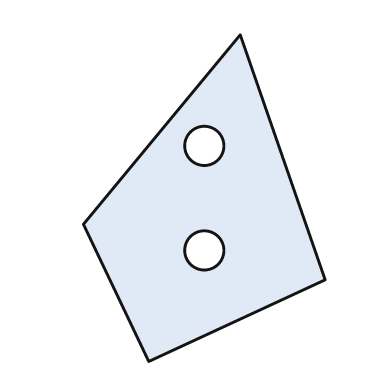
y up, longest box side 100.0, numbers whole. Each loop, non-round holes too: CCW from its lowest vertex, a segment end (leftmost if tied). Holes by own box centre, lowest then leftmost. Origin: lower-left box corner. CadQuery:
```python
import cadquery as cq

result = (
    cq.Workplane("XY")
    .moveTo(20.0, 0.0)
    .lineTo(74.0, 25.0)
    .lineTo(48.0, 100.0)
    .lineTo(0.0, 42.0)
    .close()
    .moveTo(37.0, 34.0)
    .circle(6.0)
    .moveTo(37.0, 66.0)
    .circle(6.0)
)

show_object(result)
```